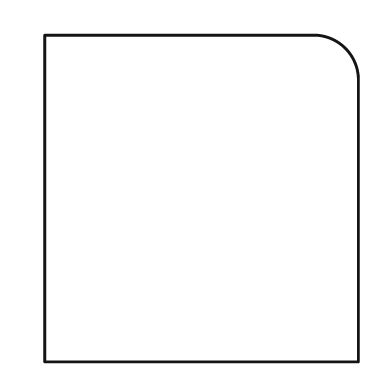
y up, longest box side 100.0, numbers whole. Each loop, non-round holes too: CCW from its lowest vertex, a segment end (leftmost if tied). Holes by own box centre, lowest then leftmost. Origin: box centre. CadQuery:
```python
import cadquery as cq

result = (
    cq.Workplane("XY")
    .moveTo(-48.0, -50.0)
    .lineTo(48.0, -50.0)
    .lineTo(48.0, 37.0)
    .threePointArc((44.0, 46.0), (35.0, 50.0))
    .lineTo(-48.0, 50.0)
    .close()
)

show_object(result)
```